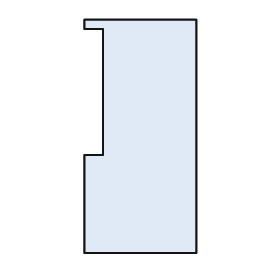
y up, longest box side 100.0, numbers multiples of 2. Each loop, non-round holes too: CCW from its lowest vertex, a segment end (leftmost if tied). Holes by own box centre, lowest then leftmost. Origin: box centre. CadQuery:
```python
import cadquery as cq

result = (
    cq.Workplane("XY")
    .moveTo(-24.0, -50.0)
    .lineTo(24.0, -50.0)
    .lineTo(24.0, 50.0)
    .lineTo(-24.0, 50.0)
    .lineTo(-24.0, 46.0)
    .lineTo(-16.0, 46.0)
    .lineTo(-16.0, -8.0)
    .lineTo(-24.0, -8.0)
    .close()
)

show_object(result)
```